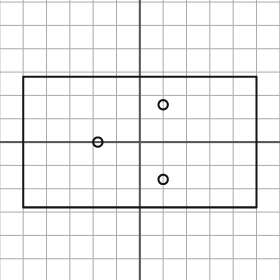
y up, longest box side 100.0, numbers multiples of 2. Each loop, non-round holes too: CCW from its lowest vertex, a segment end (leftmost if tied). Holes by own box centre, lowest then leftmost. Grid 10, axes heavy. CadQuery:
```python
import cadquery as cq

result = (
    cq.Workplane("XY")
    .moveTo(-50.0, -28.0)
    .lineTo(50.0, -28.0)
    .lineTo(50.0, 28.0)
    .lineTo(-50.0, 28.0)
    .close()
    .moveTo(10.0, -16.0)
    .circle(2.0)
    .moveTo(-18.0, 0.0)
    .circle(2.0)
    .moveTo(10.0, 16.0)
    .circle(2.0)
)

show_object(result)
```